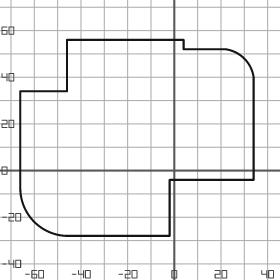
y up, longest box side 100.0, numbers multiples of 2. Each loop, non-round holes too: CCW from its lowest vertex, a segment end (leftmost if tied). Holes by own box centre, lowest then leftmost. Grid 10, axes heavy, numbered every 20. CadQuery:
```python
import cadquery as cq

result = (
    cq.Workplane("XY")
    .moveTo(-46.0, -28.0)
    .lineTo(-2.0, -28.0)
    .lineTo(-2.0, -4.0)
    .lineTo(34.0, -4.0)
    .lineTo(34.0, 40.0)
    .threePointArc((30.0, 48.0), (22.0, 52.0))
    .lineTo(4.0, 52.0)
    .lineTo(4.0, 56.0)
    .lineTo(-46.0, 56.0)
    .lineTo(-46.0, 34.0)
    .lineTo(-66.0, 34.0)
    .lineTo(-66.0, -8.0)
    .threePointArc((-60.0, -22.0), (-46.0, -28.0))
    .close()
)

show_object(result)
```